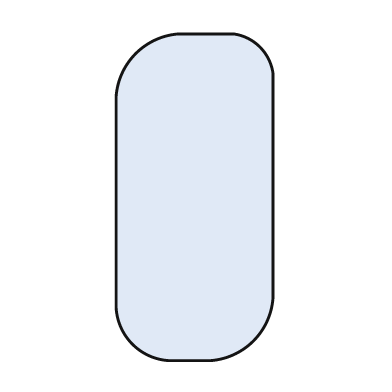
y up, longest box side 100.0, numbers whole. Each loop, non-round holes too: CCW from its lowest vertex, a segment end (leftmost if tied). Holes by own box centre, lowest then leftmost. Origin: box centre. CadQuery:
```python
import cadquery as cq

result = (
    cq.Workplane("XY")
    .moveTo(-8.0, -50.0)
    .lineTo(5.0, -50.0)
    .threePointArc((18.0, -44.0), (24.0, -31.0))
    .lineTo(24.0, 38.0)
    .threePointArc((20.0, 46.0), (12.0, 50.0))
    .lineTo(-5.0, 50.0)
    .threePointArc((-18.0, 44.0), (-24.0, 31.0))
    .lineTo(-24.0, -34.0)
    .threePointArc((-19.0, -45.0), (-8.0, -50.0))
    .close()
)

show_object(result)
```